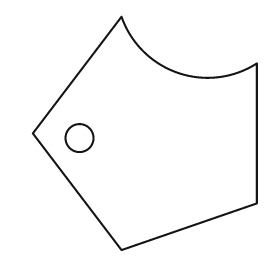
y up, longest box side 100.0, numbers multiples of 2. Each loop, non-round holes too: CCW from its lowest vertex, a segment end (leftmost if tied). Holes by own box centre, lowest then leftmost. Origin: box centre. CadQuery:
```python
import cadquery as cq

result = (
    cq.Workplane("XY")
    .moveTo(-10.0, -50.0)
    .lineTo(48.0, -30.0)
    .lineTo(48.0, 30.0)
    .threePointArc((14.0, 26.0), (-10.0, 50.0))
    .lineTo(-48.0, 0.0)
    .close()
    .moveTo(-28.0, -2.0)
    .circle(6.0)
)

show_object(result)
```